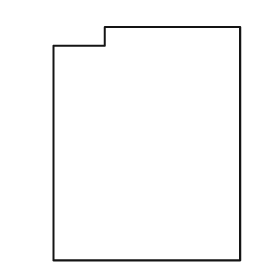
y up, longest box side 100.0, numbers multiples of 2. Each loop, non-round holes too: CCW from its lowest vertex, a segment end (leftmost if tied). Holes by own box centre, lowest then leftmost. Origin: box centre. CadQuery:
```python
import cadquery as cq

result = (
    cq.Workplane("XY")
    .moveTo(-40.0, -50.0)
    .lineTo(40.0, -50.0)
    .lineTo(40.0, 50.0)
    .lineTo(-18.0, 50.0)
    .lineTo(-18.0, 42.0)
    .lineTo(-40.0, 42.0)
    .close()
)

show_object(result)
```